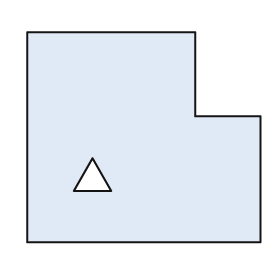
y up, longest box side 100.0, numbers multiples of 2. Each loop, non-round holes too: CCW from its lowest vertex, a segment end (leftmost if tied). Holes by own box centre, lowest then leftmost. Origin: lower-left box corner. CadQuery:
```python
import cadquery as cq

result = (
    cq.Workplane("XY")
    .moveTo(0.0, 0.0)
    .lineTo(100.0, 0.0)
    .lineTo(100.0, 54.0)
    .lineTo(72.0, 54.0)
    .lineTo(72.0, 90.0)
    .lineTo(0.0, 90.0)
    .close()
    .moveTo(20.0, 22.0)
    .lineTo(36.0, 22.0)
    .lineTo(28.0, 36.0)
    .close()
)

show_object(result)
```